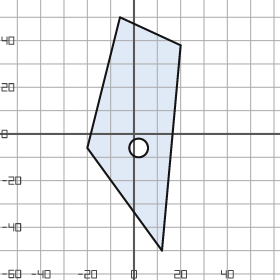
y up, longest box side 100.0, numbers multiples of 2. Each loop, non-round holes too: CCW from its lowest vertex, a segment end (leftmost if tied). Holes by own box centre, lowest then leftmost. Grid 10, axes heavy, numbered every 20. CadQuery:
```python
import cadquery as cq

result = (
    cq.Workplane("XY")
    .moveTo(12.0, -50.0)
    .lineTo(20.0, 38.0)
    .lineTo(-6.0, 50.0)
    .lineTo(-20.0, -6.0)
    .close()
    .moveTo(2.0, -6.0)
    .circle(4.0)
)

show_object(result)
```